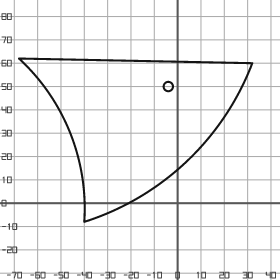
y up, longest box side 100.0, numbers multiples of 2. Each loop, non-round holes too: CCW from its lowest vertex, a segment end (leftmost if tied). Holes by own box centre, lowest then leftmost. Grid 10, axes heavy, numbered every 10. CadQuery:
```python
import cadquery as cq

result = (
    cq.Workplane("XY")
    .moveTo(-40.0, -8.0)
    .threePointArc((4.0, 18.0), (32.0, 60.0))
    .lineTo(-68.0, 62.0)
    .threePointArc((-46.0, 30.0), (-40.0, -8.0))
    .close()
    .moveTo(-4.0, 50.0)
    .circle(2.0)
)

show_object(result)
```